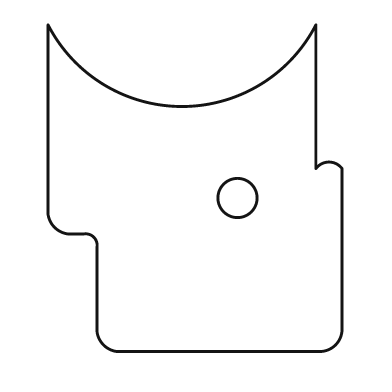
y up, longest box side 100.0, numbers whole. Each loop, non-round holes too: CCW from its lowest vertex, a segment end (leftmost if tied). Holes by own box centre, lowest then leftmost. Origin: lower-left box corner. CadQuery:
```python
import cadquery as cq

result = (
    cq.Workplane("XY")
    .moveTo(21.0, 0.0)
    .lineTo(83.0, 0.0)
    .threePointArc((88.0, 2.0), (90.0, 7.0))
    .lineTo(90.0, 56.0)
    .threePointArc((86.0, 58.0), (82.0, 56.0))
    .lineTo(82.0, 100.0)
    .threePointArc((41.0, 75.0), (0.0, 100.0))
    .lineTo(0.0, 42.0)
    .threePointArc((2.0, 38.0), (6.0, 36.0))
    .lineTo(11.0, 36.0)
    .threePointArc((14.0, 35.0), (15.0, 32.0))
    .lineTo(15.0, 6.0)
    .threePointArc((17.0, 2.0), (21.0, 0.0))
    .close()
    .moveTo(58.0, 47.0)
    .circle(6.0)
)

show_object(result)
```